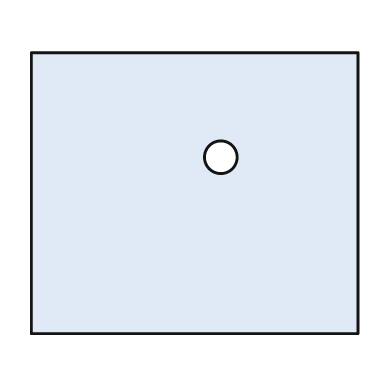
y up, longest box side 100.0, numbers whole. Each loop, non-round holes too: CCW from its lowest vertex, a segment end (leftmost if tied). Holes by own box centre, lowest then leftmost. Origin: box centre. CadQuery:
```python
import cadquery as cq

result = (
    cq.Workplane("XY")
    .moveTo(-50.0, -43.0)
    .lineTo(50.0, -43.0)
    .lineTo(50.0, 43.0)
    .lineTo(-50.0, 43.0)
    .close()
    .moveTo(8.0, 11.0)
    .circle(5.0)
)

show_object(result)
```